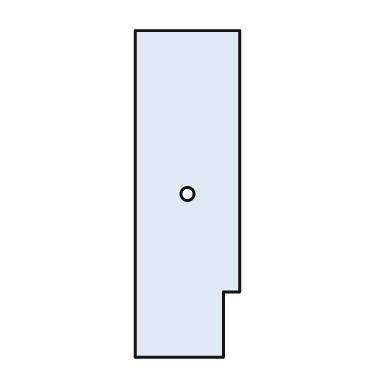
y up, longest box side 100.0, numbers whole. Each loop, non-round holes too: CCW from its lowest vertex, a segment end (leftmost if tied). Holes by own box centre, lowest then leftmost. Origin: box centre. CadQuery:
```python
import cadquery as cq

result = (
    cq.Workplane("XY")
    .moveTo(-16.0, -50.0)
    .lineTo(11.0, -50.0)
    .lineTo(11.0, -30.0)
    .lineTo(16.0, -30.0)
    .lineTo(16.0, 50.0)
    .lineTo(-16.0, 50.0)
    .close()
    .moveTo(0.0, 0.0)
    .circle(2.0)
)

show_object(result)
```